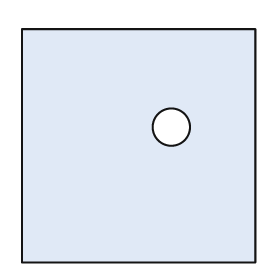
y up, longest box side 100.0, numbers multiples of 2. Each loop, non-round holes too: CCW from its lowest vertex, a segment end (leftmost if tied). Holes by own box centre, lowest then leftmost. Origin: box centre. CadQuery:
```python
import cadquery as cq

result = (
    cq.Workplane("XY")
    .moveTo(-50.0, -50.0)
    .lineTo(50.0, -50.0)
    .lineTo(50.0, 50.0)
    .lineTo(-50.0, 50.0)
    .close()
    .moveTo(14.0, 8.0)
    .circle(8.0)
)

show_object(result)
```